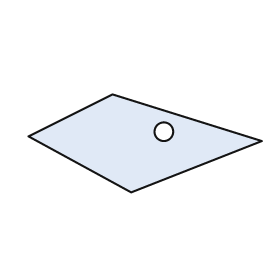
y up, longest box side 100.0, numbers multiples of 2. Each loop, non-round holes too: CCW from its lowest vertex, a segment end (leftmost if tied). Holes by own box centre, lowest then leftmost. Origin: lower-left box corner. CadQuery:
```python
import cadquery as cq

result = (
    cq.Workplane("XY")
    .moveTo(44.0, 0.0)
    .lineTo(100.0, 22.0)
    .lineTo(36.0, 42.0)
    .lineTo(0.0, 24.0)
    .close()
    .moveTo(58.0, 26.0)
    .circle(4.0)
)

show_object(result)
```